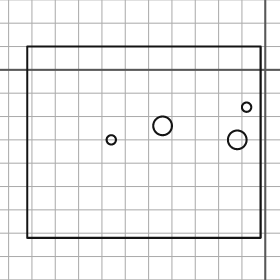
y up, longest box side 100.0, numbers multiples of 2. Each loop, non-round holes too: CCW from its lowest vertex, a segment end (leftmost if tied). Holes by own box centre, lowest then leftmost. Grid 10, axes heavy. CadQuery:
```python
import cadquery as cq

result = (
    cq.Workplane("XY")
    .moveTo(-102.0, -72.0)
    .lineTo(-2.0, -72.0)
    .lineTo(-2.0, 10.0)
    .lineTo(-102.0, 10.0)
    .close()
    .moveTo(-66.0, -30.0)
    .circle(2.0)
    .moveTo(-12.0, -30.0)
    .circle(4.0)
    .moveTo(-44.0, -24.0)
    .circle(4.0)
    .moveTo(-8.0, -16.0)
    .circle(2.0)
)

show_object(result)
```